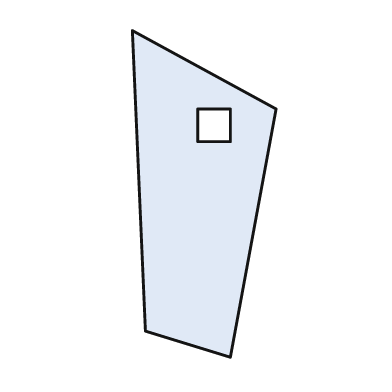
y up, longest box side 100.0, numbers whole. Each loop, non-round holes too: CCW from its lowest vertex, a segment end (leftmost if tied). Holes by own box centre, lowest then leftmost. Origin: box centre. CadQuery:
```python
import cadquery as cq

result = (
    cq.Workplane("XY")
    .moveTo(8.0, -50.0)
    .lineTo(22.0, 26.0)
    .lineTo(-22.0, 50.0)
    .lineTo(-18.0, -42.0)
    .close()
    .moveTo(-2.0, 16.0)
    .lineTo(8.0, 16.0)
    .lineTo(8.0, 26.0)
    .lineTo(-2.0, 26.0)
    .close()
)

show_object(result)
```